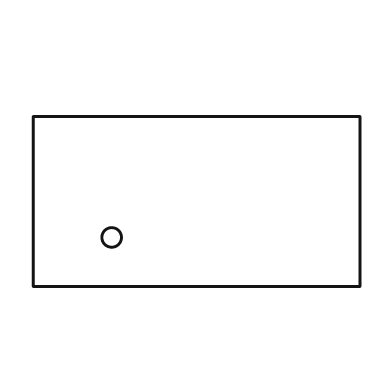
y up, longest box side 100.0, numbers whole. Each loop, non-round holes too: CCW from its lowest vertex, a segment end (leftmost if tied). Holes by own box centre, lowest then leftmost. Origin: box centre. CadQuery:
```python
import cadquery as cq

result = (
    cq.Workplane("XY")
    .moveTo(-50.0, -26.0)
    .lineTo(50.0, -26.0)
    .lineTo(50.0, 26.0)
    .lineTo(-50.0, 26.0)
    .close()
    .moveTo(-26.0, -11.0)
    .circle(3.0)
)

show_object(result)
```